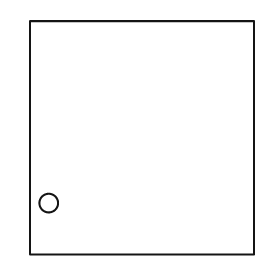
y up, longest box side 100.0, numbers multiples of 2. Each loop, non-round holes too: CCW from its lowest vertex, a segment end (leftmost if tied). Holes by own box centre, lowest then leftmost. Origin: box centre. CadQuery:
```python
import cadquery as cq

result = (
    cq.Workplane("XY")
    .moveTo(-48.0, -50.0)
    .lineTo(48.0, -50.0)
    .lineTo(48.0, 50.0)
    .lineTo(-48.0, 50.0)
    .close()
    .moveTo(-40.0, -28.0)
    .circle(4.0)
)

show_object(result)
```